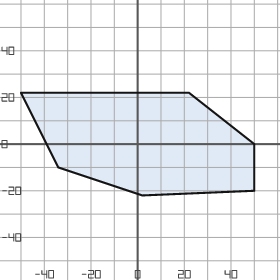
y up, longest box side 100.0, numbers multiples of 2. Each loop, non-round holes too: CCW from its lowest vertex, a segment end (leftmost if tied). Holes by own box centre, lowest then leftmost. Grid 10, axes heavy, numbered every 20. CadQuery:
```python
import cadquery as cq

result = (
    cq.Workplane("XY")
    .moveTo(2.0, -22.0)
    .lineTo(50.0, -20.0)
    .lineTo(50.0, 0.0)
    .lineTo(22.0, 22.0)
    .lineTo(-50.0, 22.0)
    .lineTo(-34.0, -10.0)
    .close()
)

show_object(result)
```